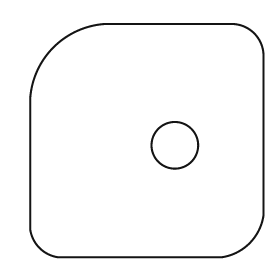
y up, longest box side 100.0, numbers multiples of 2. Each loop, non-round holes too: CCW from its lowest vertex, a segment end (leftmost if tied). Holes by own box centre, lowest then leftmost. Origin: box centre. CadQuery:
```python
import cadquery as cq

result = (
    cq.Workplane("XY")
    .moveTo(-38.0, -50.0)
    .lineTo(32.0, -50.0)
    .threePointArc((44.0, -44.0), (50.0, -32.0))
    .lineTo(50.0, 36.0)
    .threePointArc((46.0, 46.0), (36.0, 50.0))
    .lineTo(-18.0, 50.0)
    .threePointArc((-40.0, 40.0), (-50.0, 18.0))
    .lineTo(-50.0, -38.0)
    .threePointArc((-46.0, -46.0), (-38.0, -50.0))
    .close()
    .moveTo(12.0, -2.0)
    .circle(10.0)
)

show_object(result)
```